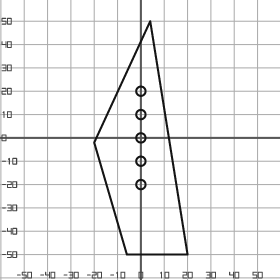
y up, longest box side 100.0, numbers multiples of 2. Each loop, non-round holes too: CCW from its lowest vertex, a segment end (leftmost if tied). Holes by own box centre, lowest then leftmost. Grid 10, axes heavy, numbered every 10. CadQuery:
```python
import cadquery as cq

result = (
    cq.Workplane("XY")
    .moveTo(-6.0, -50.0)
    .lineTo(20.0, -50.0)
    .lineTo(4.0, 50.0)
    .lineTo(-20.0, -2.0)
    .close()
    .moveTo(0.0, -20.0)
    .circle(2.0)
    .moveTo(0.0, -10.0)
    .circle(2.0)
    .moveTo(0.0, 0.0)
    .circle(2.0)
    .moveTo(0.0, 10.0)
    .circle(2.0)
    .moveTo(0.0, 20.0)
    .circle(2.0)
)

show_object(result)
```